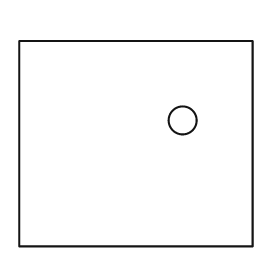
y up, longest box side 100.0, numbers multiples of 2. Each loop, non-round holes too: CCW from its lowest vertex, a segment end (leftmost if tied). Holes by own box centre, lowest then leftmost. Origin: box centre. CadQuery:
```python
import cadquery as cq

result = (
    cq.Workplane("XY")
    .moveTo(-50.0, -44.0)
    .lineTo(50.0, -44.0)
    .lineTo(50.0, 44.0)
    .lineTo(-50.0, 44.0)
    .close()
    .moveTo(20.0, 10.0)
    .circle(6.0)
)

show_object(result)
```